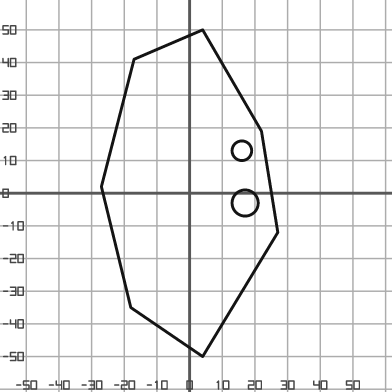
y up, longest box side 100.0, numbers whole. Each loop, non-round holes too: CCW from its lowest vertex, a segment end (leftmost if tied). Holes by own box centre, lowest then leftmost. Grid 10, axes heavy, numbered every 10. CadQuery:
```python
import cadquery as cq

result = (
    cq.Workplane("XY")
    .moveTo(4.0, -50.0)
    .lineTo(27.0, -12.0)
    .lineTo(22.0, 19.0)
    .lineTo(4.0, 50.0)
    .lineTo(-17.0, 41.0)
    .lineTo(-27.0, 2.0)
    .lineTo(-18.0, -35.0)
    .close()
    .moveTo(17.0, -3.0)
    .circle(4.0)
    .moveTo(16.0, 13.0)
    .circle(3.0)
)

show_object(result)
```